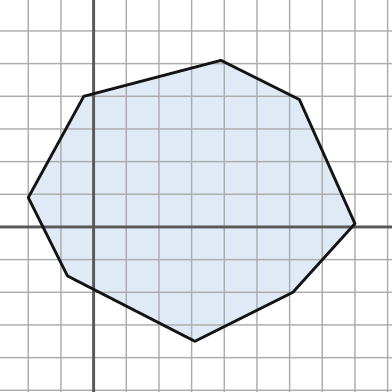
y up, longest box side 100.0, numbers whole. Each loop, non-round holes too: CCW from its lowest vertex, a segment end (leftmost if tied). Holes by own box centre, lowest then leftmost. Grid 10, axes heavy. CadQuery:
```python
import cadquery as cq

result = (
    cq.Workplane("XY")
    .moveTo(31.0, -35.0)
    .lineTo(61.0, -20.0)
    .lineTo(80.0, 1.0)
    .lineTo(63.0, 39.0)
    .lineTo(39.0, 51.0)
    .lineTo(-3.0, 40.0)
    .lineTo(-20.0, 9.0)
    .lineTo(-8.0, -15.0)
    .close()
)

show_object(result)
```